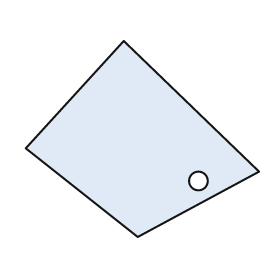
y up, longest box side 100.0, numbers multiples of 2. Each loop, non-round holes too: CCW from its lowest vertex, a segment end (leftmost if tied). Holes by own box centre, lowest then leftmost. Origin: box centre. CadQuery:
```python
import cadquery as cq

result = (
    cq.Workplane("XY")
    .moveTo(-2.0, -42.0)
    .lineTo(50.0, -14.0)
    .lineTo(-8.0, 42.0)
    .lineTo(-50.0, -4.0)
    .close()
    .moveTo(24.0, -18.0)
    .circle(4.0)
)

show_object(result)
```